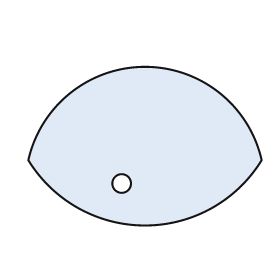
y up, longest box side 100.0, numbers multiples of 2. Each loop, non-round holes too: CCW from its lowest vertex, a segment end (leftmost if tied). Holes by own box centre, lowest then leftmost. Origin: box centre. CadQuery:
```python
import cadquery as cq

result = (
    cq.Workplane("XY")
    .moveTo(-50.0, -6.0)
    .threePointArc((0.0, -34.0), (50.0, -6.0))
    .threePointArc((0.0, 34.0), (-50.0, -6.0))
    .close()
    .moveTo(-10.0, -16.0)
    .circle(4.0)
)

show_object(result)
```